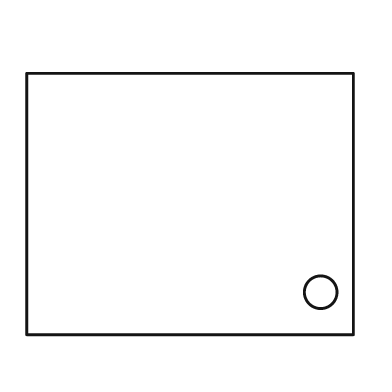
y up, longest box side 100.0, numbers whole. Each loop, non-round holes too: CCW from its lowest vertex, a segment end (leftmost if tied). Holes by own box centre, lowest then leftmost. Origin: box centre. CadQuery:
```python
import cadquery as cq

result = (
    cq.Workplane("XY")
    .moveTo(-50.0, -40.0)
    .lineTo(50.0, -40.0)
    .lineTo(50.0, 40.0)
    .lineTo(-50.0, 40.0)
    .close()
    .moveTo(40.0, -27.0)
    .circle(5.0)
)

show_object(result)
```